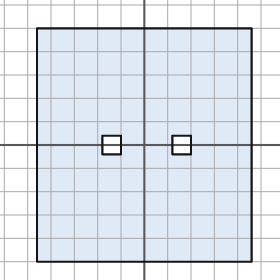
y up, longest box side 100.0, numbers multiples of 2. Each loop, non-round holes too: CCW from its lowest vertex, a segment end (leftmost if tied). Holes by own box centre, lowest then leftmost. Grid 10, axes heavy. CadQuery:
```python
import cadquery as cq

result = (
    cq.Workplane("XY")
    .moveTo(-46.0, -50.0)
    .lineTo(46.0, -50.0)
    .lineTo(46.0, 50.0)
    .lineTo(-46.0, 50.0)
    .close()
    .moveTo(-18.0, -4.0)
    .lineTo(-10.0, -4.0)
    .lineTo(-10.0, 4.0)
    .lineTo(-18.0, 4.0)
    .close()
    .moveTo(12.0, -4.0)
    .lineTo(20.0, -4.0)
    .lineTo(20.0, 4.0)
    .lineTo(12.0, 4.0)
    .close()
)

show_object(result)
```